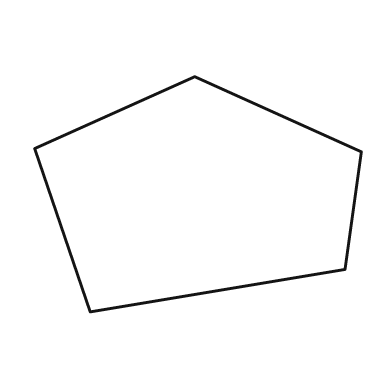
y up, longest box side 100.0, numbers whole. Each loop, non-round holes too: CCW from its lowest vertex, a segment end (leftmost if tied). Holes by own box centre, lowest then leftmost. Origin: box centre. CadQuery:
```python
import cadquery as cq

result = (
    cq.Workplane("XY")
    .moveTo(-33.0, -36.0)
    .lineTo(45.0, -23.0)
    .lineTo(50.0, 13.0)
    .lineTo(-1.0, 36.0)
    .lineTo(-50.0, 14.0)
    .close()
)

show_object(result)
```